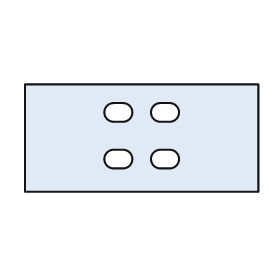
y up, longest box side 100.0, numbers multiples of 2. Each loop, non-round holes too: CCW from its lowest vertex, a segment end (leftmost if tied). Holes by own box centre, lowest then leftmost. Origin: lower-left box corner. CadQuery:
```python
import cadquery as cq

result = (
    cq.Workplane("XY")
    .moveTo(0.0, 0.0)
    .lineTo(100.0, 0.0)
    .lineTo(100.0, 46.0)
    .lineTo(0.0, 46.0)
    .close()
    .moveTo(38.0, 10.0)
    .lineTo(42.0, 10.0)
    .threePointArc((46.0, 14.0), (42.0, 18.0))
    .lineTo(38.0, 18.0)
    .threePointArc((34.0, 14.0), (38.0, 10.0))
    .close()
    .moveTo(58.0, 10.0)
    .lineTo(62.0, 10.0)
    .threePointArc((66.0, 14.0), (62.0, 18.0))
    .lineTo(58.0, 18.0)
    .threePointArc((54.0, 14.0), (58.0, 10.0))
    .close()
    .moveTo(38.0, 30.0)
    .lineTo(42.0, 30.0)
    .threePointArc((46.0, 34.0), (42.0, 38.0))
    .lineTo(38.0, 38.0)
    .threePointArc((34.0, 34.0), (38.0, 30.0))
    .close()
    .moveTo(58.0, 30.0)
    .lineTo(62.0, 30.0)
    .threePointArc((66.0, 34.0), (62.0, 38.0))
    .lineTo(58.0, 38.0)
    .threePointArc((54.0, 34.0), (58.0, 30.0))
    .close()
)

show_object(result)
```